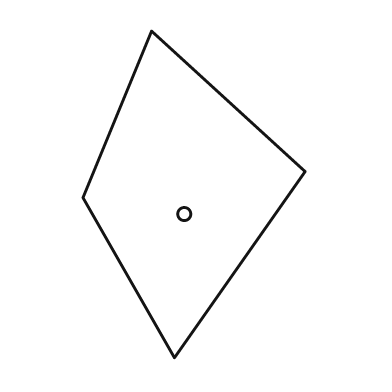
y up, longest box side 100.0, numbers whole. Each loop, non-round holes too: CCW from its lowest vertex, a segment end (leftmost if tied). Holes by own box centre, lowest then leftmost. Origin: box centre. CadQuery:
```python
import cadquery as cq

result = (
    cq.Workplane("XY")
    .moveTo(-6.0, -50.0)
    .lineTo(34.0, 7.0)
    .lineTo(-13.0, 50.0)
    .lineTo(-34.0, -1.0)
    .close()
    .moveTo(-3.0, -6.0)
    .circle(2.0)
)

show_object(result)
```